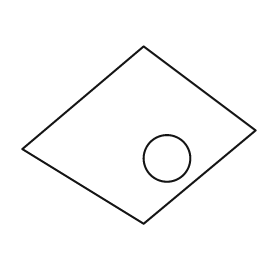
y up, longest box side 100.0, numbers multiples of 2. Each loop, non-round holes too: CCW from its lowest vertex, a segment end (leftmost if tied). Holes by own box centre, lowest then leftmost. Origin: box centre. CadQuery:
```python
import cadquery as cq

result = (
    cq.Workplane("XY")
    .moveTo(2.0, -38.0)
    .lineTo(50.0, 2.0)
    .lineTo(2.0, 38.0)
    .lineTo(-50.0, -6.0)
    .close()
    .moveTo(12.0, -10.0)
    .circle(10.0)
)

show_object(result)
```